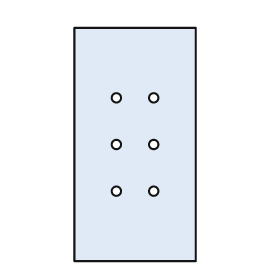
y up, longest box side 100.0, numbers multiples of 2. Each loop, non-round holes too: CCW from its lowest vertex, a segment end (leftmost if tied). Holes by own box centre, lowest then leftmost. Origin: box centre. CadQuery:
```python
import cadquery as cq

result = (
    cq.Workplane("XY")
    .moveTo(-26.0, -50.0)
    .lineTo(26.0, -50.0)
    .lineTo(26.0, 50.0)
    .lineTo(-26.0, 50.0)
    .close()
    .moveTo(-8.0, -20.0)
    .circle(2.0)
    .moveTo(8.0, -20.0)
    .circle(2.0)
    .moveTo(-8.0, 0.0)
    .circle(2.0)
    .moveTo(8.0, 0.0)
    .circle(2.0)
    .moveTo(-8.0, 20.0)
    .circle(2.0)
    .moveTo(8.0, 20.0)
    .circle(2.0)
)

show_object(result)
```